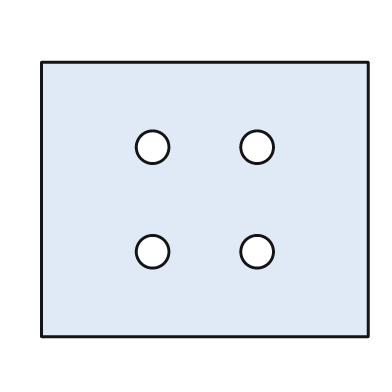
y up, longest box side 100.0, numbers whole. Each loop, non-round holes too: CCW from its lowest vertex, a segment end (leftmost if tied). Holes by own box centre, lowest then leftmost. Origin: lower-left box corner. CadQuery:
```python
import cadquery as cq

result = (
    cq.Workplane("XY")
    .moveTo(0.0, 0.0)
    .lineTo(100.0, 0.0)
    .lineTo(100.0, 84.0)
    .lineTo(0.0, 84.0)
    .close()
    .moveTo(34.0, 26.0)
    .circle(5.0)
    .moveTo(66.0, 26.0)
    .circle(5.0)
    .moveTo(34.0, 58.0)
    .circle(5.0)
    .moveTo(66.0, 58.0)
    .circle(5.0)
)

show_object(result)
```